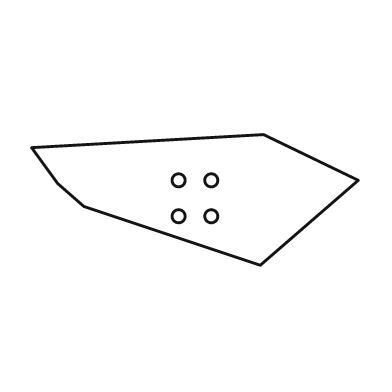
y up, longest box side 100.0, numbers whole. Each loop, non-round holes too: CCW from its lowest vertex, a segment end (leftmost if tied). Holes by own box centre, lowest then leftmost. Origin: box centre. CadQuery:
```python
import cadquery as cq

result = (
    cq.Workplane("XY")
    .moveTo(20.0, -20.0)
    .lineTo(50.0, 6.0)
    .lineTo(21.0, 20.0)
    .lineTo(-50.0, 16.0)
    .lineTo(-42.0, 5.0)
    .lineTo(-34.0, -2.0)
    .close()
    .moveTo(-5.0, -5.0)
    .circle(2.0)
    .moveTo(5.0, -5.0)
    .circle(2.0)
    .moveTo(-5.0, 6.0)
    .circle(2.0)
    .moveTo(5.0, 6.0)
    .circle(2.0)
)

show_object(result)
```